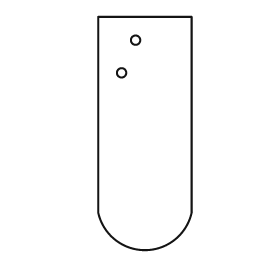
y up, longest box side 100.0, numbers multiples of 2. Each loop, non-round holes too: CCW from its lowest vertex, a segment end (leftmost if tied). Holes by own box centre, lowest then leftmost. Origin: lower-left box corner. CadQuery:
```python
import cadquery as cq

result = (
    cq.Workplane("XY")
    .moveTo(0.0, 16.0)
    .threePointArc((20.0, 0.0), (40.0, 16.0))
    .lineTo(40.0, 100.0)
    .lineTo(0.0, 100.0)
    .close()
    .moveTo(10.0, 76.0)
    .circle(2.0)
    .moveTo(16.0, 90.0)
    .circle(2.0)
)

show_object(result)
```